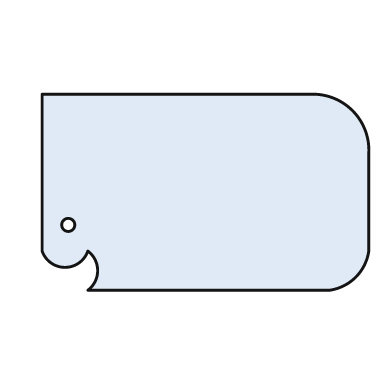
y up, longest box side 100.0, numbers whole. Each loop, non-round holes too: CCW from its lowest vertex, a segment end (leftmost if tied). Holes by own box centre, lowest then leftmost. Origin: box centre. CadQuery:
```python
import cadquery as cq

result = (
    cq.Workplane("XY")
    .moveTo(-36.0, -30.0)
    .lineTo(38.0, -30.0)
    .threePointArc((46.0, -26.0), (50.0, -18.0))
    .lineTo(50.0, 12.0)
    .threePointArc((45.0, 25.0), (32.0, 30.0))
    .lineTo(-50.0, 30.0)
    .lineTo(-50.0, -18.0)
    .threePointArc((-43.0, -23.0), (-36.0, -18.0))
    .threePointArc((-33.0, -24.0), (-36.0, -30.0))
    .close()
    .moveTo(-42.0, -10.0)
    .circle(2.0)
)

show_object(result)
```